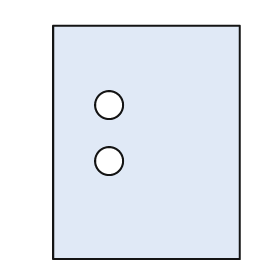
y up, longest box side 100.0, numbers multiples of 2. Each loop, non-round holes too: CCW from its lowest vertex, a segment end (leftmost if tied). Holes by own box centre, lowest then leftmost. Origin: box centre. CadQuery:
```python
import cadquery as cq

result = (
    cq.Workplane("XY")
    .moveTo(-40.0, -50.0)
    .lineTo(40.0, -50.0)
    .lineTo(40.0, 50.0)
    .lineTo(-40.0, 50.0)
    .close()
    .moveTo(-16.0, -8.0)
    .circle(6.0)
    .moveTo(-16.0, 16.0)
    .circle(6.0)
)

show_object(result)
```